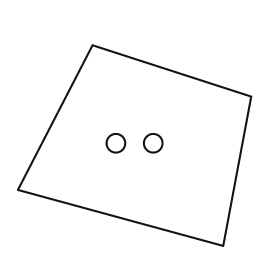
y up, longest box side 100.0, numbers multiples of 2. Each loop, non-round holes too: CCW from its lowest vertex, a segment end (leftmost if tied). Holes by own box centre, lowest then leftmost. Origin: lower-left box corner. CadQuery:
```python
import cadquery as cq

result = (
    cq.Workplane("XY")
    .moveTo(88.0, 0.0)
    .lineTo(100.0, 64.0)
    .lineTo(32.0, 86.0)
    .lineTo(0.0, 24.0)
    .close()
    .moveTo(42.0, 44.0)
    .circle(4.0)
    .moveTo(58.0, 44.0)
    .circle(4.0)
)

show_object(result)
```